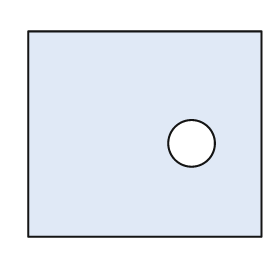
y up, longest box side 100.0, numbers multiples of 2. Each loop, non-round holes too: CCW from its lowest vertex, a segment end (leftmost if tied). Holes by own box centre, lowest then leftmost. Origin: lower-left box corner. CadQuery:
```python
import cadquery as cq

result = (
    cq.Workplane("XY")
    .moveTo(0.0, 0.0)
    .lineTo(100.0, 0.0)
    .lineTo(100.0, 88.0)
    .lineTo(0.0, 88.0)
    .close()
    .moveTo(70.0, 40.0)
    .circle(10.0)
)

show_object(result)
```